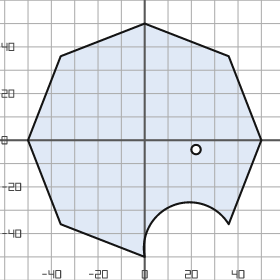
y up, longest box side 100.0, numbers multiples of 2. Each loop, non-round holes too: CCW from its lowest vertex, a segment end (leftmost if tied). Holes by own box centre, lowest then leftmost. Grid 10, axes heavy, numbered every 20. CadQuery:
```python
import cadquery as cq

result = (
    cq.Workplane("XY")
    .moveTo(0.0, -50.0)
    .threePointArc((12.0, -28.0), (36.0, -36.0))
    .lineTo(50.0, 0.0)
    .lineTo(36.0, 36.0)
    .lineTo(0.0, 50.0)
    .lineTo(-36.0, 36.0)
    .lineTo(-50.0, 0.0)
    .lineTo(-36.0, -36.0)
    .close()
    .moveTo(22.0, -4.0)
    .circle(2.0)
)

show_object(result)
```